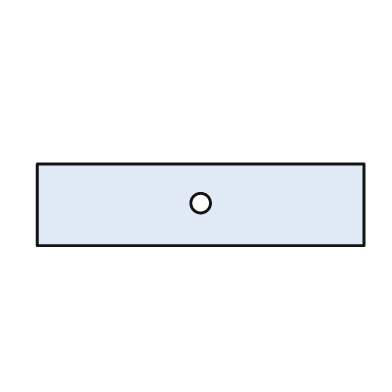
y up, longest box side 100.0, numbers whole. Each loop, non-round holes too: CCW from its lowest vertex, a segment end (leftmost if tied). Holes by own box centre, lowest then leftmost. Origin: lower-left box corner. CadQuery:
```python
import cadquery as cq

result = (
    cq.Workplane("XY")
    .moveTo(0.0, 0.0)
    .lineTo(100.0, 0.0)
    .lineTo(100.0, 25.0)
    .lineTo(0.0, 25.0)
    .close()
    .moveTo(50.0, 13.0)
    .circle(3.0)
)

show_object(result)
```